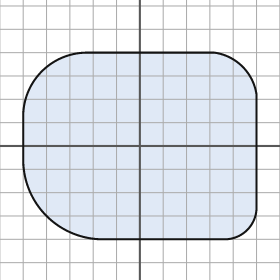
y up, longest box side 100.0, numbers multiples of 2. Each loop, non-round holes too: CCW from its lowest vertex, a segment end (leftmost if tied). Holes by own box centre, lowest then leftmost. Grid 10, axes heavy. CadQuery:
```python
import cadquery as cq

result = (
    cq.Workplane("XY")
    .moveTo(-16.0, -40.0)
    .lineTo(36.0, -40.0)
    .threePointArc((46.0, -36.0), (50.0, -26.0))
    .lineTo(50.0, 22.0)
    .threePointArc((44.0, 34.0), (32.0, 40.0))
    .lineTo(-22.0, 40.0)
    .threePointArc((-42.0, 32.0), (-50.0, 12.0))
    .lineTo(-50.0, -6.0)
    .threePointArc((-40.0, -30.0), (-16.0, -40.0))
    .close()
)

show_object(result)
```